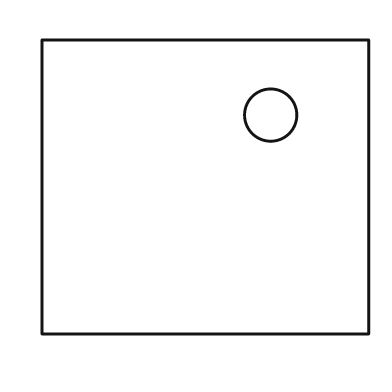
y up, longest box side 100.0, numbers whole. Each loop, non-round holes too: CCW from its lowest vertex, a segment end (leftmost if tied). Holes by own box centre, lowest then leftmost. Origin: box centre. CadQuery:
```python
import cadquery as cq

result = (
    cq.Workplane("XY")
    .moveTo(-50.0, -45.0)
    .lineTo(50.0, -45.0)
    .lineTo(50.0, 45.0)
    .lineTo(-50.0, 45.0)
    .close()
    .moveTo(20.0, 22.0)
    .circle(8.0)
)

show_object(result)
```